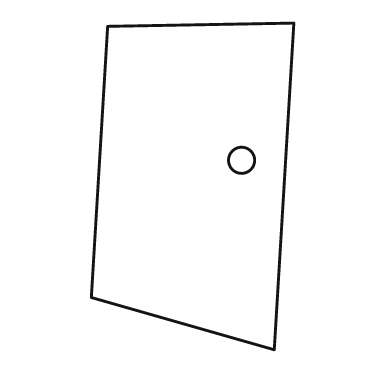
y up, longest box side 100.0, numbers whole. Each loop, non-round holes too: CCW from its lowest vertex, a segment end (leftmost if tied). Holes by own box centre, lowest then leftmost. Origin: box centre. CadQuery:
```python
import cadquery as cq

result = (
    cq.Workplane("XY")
    .moveTo(25.0, -50.0)
    .lineTo(31.0, 50.0)
    .lineTo(-26.0, 49.0)
    .lineTo(-31.0, -34.0)
    .close()
    .moveTo(15.0, 8.0)
    .circle(4.0)
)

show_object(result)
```